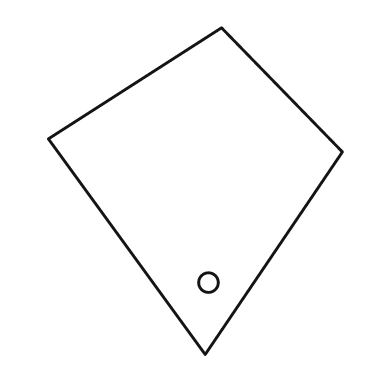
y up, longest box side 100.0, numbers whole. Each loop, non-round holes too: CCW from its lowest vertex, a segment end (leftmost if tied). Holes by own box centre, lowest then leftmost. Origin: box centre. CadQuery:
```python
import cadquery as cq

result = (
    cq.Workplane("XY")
    .moveTo(3.0, -50.0)
    .lineTo(45.0, 12.0)
    .lineTo(8.0, 50.0)
    .lineTo(-45.0, 16.0)
    .close()
    .moveTo(4.0, -28.0)
    .circle(3.0)
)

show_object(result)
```